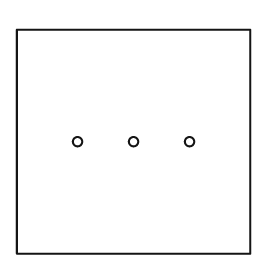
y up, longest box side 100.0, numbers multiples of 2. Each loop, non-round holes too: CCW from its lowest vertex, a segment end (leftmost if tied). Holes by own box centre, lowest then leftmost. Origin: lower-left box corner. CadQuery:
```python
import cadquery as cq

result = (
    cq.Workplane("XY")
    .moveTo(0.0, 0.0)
    .lineTo(100.0, 0.0)
    .lineTo(100.0, 96.0)
    .lineTo(0.0, 96.0)
    .close()
    .moveTo(26.0, 48.0)
    .circle(2.0)
    .moveTo(50.0, 48.0)
    .circle(2.0)
    .moveTo(74.0, 48.0)
    .circle(2.0)
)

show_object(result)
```